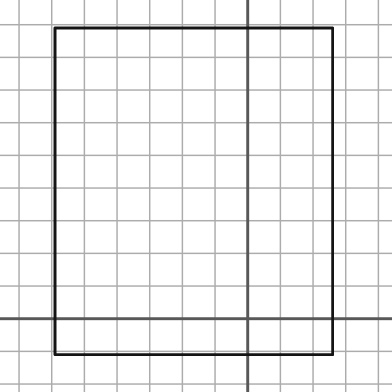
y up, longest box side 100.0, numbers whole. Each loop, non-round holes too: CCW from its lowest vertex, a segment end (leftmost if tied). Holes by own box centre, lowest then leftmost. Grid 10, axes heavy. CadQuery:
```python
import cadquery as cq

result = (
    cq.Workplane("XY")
    .moveTo(-59.0, -11.0)
    .lineTo(26.0, -11.0)
    .lineTo(26.0, 89.0)
    .lineTo(-59.0, 89.0)
    .close()
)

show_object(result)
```